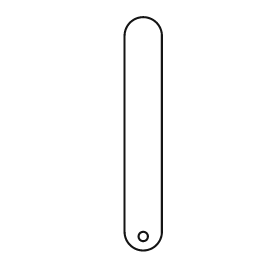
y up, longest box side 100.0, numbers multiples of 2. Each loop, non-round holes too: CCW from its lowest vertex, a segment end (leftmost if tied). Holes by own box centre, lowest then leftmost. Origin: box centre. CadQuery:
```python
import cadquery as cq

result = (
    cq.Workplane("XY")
    .moveTo(-8.0, -42.0)
    .threePointArc((0.0, -50.0), (8.0, -42.0))
    .lineTo(8.0, 42.0)
    .threePointArc((0.0, 50.0), (-8.0, 42.0))
    .close()
    .moveTo(0.0, -44.0)
    .circle(2.0)
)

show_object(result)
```